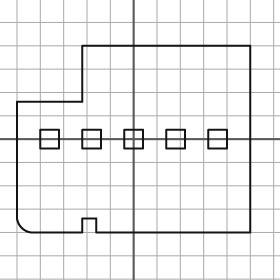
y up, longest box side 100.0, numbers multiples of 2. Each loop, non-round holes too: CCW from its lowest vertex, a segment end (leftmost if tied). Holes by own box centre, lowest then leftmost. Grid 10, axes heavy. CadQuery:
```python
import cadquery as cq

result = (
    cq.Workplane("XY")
    .moveTo(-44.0, -40.0)
    .lineTo(-22.0, -40.0)
    .lineTo(-22.0, -34.0)
    .lineTo(-16.0, -34.0)
    .lineTo(-16.0, -40.0)
    .lineTo(50.0, -40.0)
    .lineTo(50.0, 40.0)
    .lineTo(-22.0, 40.0)
    .lineTo(-22.0, 16.0)
    .lineTo(-50.0, 16.0)
    .lineTo(-50.0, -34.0)
    .threePointArc((-48.0, -38.0), (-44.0, -40.0))
    .close()
    .moveTo(-40.0, -4.0)
    .lineTo(-32.0, -4.0)
    .lineTo(-32.0, 4.0)
    .lineTo(-40.0, 4.0)
    .close()
    .moveTo(-22.0, -4.0)
    .lineTo(-14.0, -4.0)
    .lineTo(-14.0, 4.0)
    .lineTo(-22.0, 4.0)
    .close()
    .moveTo(-4.0, -4.0)
    .lineTo(4.0, -4.0)
    .lineTo(4.0, 4.0)
    .lineTo(-4.0, 4.0)
    .close()
    .moveTo(14.0, -4.0)
    .lineTo(22.0, -4.0)
    .lineTo(22.0, 4.0)
    .lineTo(14.0, 4.0)
    .close()
    .moveTo(32.0, -4.0)
    .lineTo(40.0, -4.0)
    .lineTo(40.0, 4.0)
    .lineTo(32.0, 4.0)
    .close()
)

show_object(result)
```